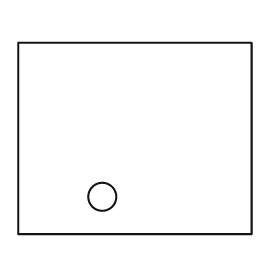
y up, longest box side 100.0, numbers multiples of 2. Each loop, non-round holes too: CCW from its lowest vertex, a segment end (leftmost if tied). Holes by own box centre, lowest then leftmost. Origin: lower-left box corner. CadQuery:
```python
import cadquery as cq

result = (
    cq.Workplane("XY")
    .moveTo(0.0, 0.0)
    .lineTo(100.0, 0.0)
    .lineTo(100.0, 82.0)
    .lineTo(0.0, 82.0)
    .close()
    .moveTo(36.0, 16.0)
    .circle(6.0)
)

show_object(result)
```